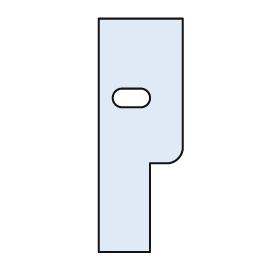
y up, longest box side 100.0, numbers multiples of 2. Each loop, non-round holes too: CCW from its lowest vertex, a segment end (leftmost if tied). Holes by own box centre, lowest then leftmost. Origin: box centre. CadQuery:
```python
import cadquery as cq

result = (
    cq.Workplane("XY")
    .moveTo(-18.0, -50.0)
    .lineTo(4.0, -50.0)
    .lineTo(4.0, -12.0)
    .lineTo(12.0, -12.0)
    .threePointArc((16.0, -10.0), (18.0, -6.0))
    .lineTo(18.0, 50.0)
    .lineTo(-18.0, 50.0)
    .close()
    .moveTo(-8.0, 12.0)
    .lineTo(0.0, 12.0)
    .threePointArc((4.0, 16.0), (0.0, 20.0))
    .lineTo(-8.0, 20.0)
    .threePointArc((-12.0, 16.0), (-8.0, 12.0))
    .close()
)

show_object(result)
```